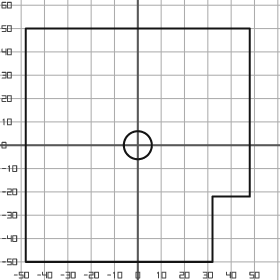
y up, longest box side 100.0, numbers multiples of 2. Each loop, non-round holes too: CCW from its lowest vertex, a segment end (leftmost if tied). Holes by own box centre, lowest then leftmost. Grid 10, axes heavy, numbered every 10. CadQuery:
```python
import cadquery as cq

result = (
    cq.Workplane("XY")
    .moveTo(-48.0, -50.0)
    .lineTo(32.0, -50.0)
    .lineTo(32.0, -22.0)
    .lineTo(48.0, -22.0)
    .lineTo(48.0, 50.0)
    .lineTo(-48.0, 50.0)
    .close()
    .moveTo(0.0, 0.0)
    .circle(6.0)
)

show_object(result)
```